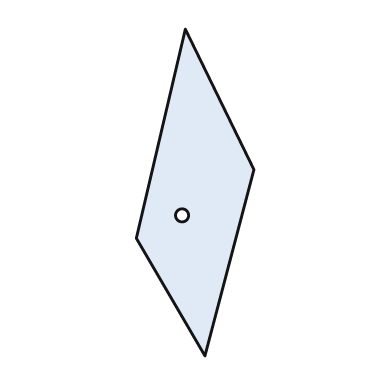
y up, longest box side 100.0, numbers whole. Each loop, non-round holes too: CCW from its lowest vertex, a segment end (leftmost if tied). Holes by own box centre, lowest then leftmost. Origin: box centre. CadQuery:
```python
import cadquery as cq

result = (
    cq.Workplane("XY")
    .moveTo(3.0, -50.0)
    .lineTo(18.0, 7.0)
    .lineTo(-3.0, 50.0)
    .lineTo(-18.0, -14.0)
    .close()
    .moveTo(-4.0, -7.0)
    .circle(2.0)
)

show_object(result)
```